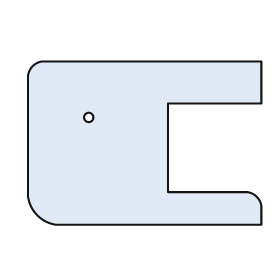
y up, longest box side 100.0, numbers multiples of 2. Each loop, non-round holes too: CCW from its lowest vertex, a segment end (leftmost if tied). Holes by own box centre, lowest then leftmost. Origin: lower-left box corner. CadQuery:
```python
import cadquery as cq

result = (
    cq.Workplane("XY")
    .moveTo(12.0, 0.0)
    .lineTo(100.0, 0.0)
    .lineTo(100.0, 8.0)
    .threePointArc((98.0, 12.0), (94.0, 14.0))
    .lineTo(60.0, 14.0)
    .lineTo(60.0, 52.0)
    .lineTo(100.0, 52.0)
    .lineTo(100.0, 70.0)
    .lineTo(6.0, 70.0)
    .threePointArc((2.0, 68.0), (0.0, 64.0))
    .lineTo(0.0, 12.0)
    .threePointArc((4.0, 4.0), (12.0, 0.0))
    .close()
    .moveTo(26.0, 46.0)
    .circle(2.0)
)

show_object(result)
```